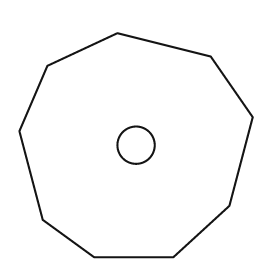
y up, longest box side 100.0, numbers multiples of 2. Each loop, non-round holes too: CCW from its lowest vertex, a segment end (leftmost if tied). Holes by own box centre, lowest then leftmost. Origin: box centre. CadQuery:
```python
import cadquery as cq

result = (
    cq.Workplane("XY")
    .moveTo(-18.0, -48.0)
    .lineTo(16.0, -48.0)
    .lineTo(40.0, -26.0)
    .lineTo(50.0, 12.0)
    .lineTo(32.0, 38.0)
    .lineTo(-8.0, 48.0)
    .lineTo(-38.0, 34.0)
    .lineTo(-50.0, 6.0)
    .lineTo(-40.0, -32.0)
    .close()
    .moveTo(0.0, 0.0)
    .circle(8.0)
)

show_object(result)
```